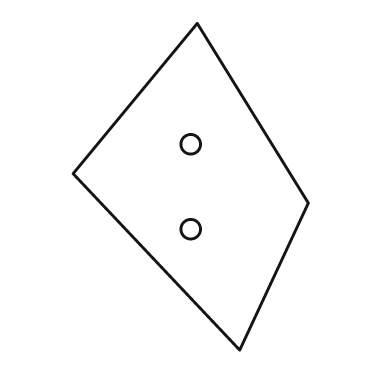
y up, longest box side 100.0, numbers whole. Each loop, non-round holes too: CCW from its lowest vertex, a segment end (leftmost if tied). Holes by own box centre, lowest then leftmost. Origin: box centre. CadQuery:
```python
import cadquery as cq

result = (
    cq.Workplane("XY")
    .moveTo(15.0, -50.0)
    .lineTo(36.0, -5.0)
    .lineTo(2.0, 50.0)
    .lineTo(-36.0, 4.0)
    .close()
    .moveTo(0.0, -13.0)
    .circle(3.0)
    .moveTo(0.0, 13.0)
    .circle(3.0)
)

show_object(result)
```